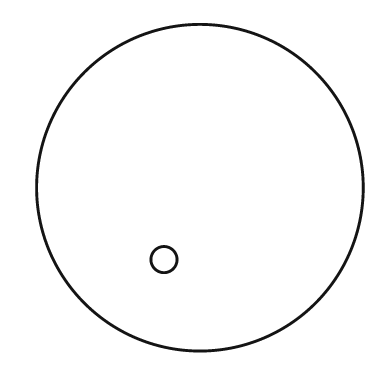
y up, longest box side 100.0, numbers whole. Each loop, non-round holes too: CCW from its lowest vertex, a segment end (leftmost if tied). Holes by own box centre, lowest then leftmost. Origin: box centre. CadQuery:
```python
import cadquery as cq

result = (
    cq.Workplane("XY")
    .moveTo(0.0, 0.0)
    .circle(50.0)
    .moveTo(-11.0, -22.0)
    .circle(4.0)
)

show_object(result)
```